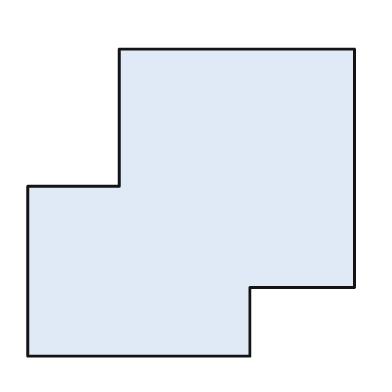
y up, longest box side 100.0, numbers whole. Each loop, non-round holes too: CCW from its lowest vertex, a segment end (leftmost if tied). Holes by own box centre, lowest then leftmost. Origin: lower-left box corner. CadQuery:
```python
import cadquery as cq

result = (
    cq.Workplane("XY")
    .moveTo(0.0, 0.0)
    .lineTo(68.0, 0.0)
    .lineTo(68.0, 21.0)
    .lineTo(100.0, 21.0)
    .lineTo(100.0, 94.0)
    .lineTo(28.0, 94.0)
    .lineTo(28.0, 52.0)
    .lineTo(0.0, 52.0)
    .close()
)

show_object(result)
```